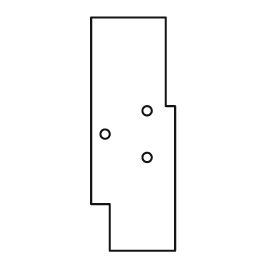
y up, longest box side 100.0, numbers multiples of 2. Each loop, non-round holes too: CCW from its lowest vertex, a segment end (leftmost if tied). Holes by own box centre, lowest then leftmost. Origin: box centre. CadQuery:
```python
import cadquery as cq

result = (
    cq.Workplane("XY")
    .moveTo(-10.0, -50.0)
    .lineTo(18.0, -50.0)
    .lineTo(18.0, 12.0)
    .lineTo(14.0, 12.0)
    .lineTo(14.0, 50.0)
    .lineTo(-18.0, 50.0)
    .lineTo(-18.0, -30.0)
    .lineTo(-10.0, -30.0)
    .close()
    .moveTo(6.0, -10.0)
    .circle(2.0)
    .moveTo(-12.0, 0.0)
    .circle(2.0)
    .moveTo(6.0, 10.0)
    .circle(2.0)
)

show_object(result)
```